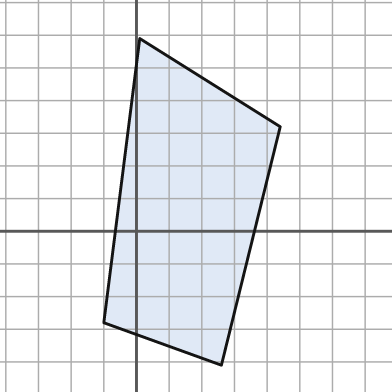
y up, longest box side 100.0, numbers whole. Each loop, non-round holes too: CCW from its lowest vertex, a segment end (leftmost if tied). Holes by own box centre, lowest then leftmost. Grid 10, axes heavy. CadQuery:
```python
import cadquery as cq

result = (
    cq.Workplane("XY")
    .moveTo(26.0, -41.0)
    .lineTo(44.0, 32.0)
    .lineTo(1.0, 59.0)
    .lineTo(-10.0, -28.0)
    .close()
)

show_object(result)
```